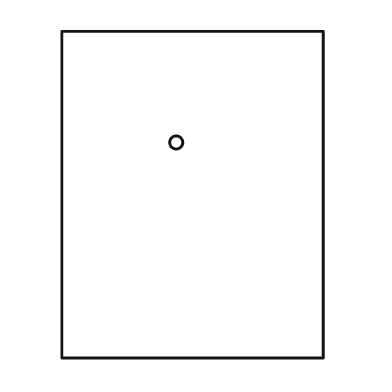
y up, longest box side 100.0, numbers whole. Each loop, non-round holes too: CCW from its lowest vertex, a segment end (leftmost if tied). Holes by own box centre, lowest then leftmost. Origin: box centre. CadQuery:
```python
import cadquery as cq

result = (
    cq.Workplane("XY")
    .moveTo(-40.0, -50.0)
    .lineTo(40.0, -50.0)
    .lineTo(40.0, 50.0)
    .lineTo(-40.0, 50.0)
    .close()
    .moveTo(-5.0, 16.0)
    .circle(2.0)
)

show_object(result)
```